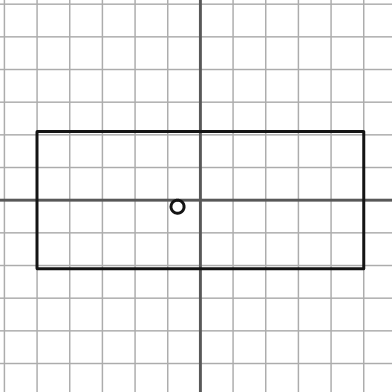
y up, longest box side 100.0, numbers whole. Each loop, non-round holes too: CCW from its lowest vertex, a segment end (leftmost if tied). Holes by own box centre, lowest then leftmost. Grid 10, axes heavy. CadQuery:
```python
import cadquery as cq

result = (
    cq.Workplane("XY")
    .moveTo(-50.0, -21.0)
    .lineTo(50.0, -21.0)
    .lineTo(50.0, 21.0)
    .lineTo(-50.0, 21.0)
    .close()
    .moveTo(-7.0, -2.0)
    .circle(2.0)
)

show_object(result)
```